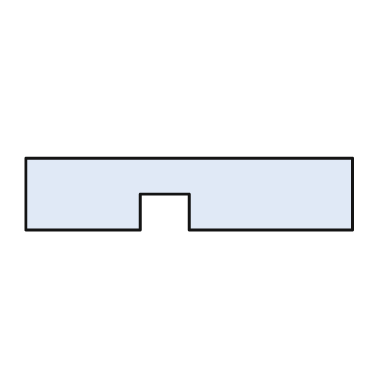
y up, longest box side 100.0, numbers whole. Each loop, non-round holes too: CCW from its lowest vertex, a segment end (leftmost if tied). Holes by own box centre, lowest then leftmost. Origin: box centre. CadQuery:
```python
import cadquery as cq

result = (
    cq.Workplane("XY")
    .moveTo(-50.0, -11.0)
    .lineTo(-15.0, -11.0)
    .lineTo(-15.0, 0.0)
    .lineTo(0.0, 0.0)
    .lineTo(0.0, -11.0)
    .lineTo(50.0, -11.0)
    .lineTo(50.0, 11.0)
    .lineTo(-50.0, 11.0)
    .close()
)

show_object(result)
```